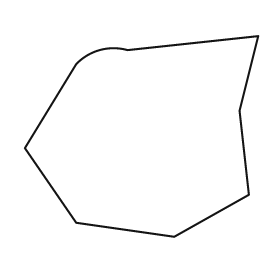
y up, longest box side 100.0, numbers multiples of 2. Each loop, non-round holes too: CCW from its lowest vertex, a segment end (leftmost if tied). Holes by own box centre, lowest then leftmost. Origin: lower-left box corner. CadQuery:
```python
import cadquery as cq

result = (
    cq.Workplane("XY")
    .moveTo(64.0, 0.0)
    .lineTo(96.0, 18.0)
    .lineTo(92.0, 54.0)
    .lineTo(100.0, 86.0)
    .lineTo(44.0, 80.0)
    .threePointArc((32.0, 80.0), (22.0, 74.0))
    .lineTo(0.0, 38.0)
    .lineTo(22.0, 6.0)
    .close()
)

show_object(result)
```